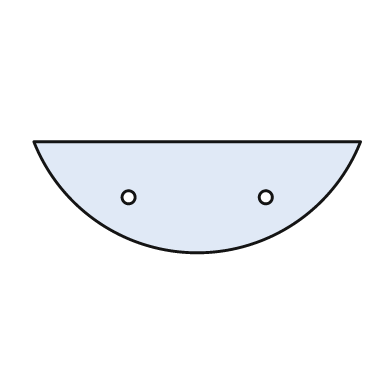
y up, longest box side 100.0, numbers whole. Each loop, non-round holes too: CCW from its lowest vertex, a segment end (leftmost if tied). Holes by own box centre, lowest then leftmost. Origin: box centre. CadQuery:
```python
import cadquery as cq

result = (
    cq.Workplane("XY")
    .moveTo(-50.0, 17.0)
    .threePointArc((0.0, -17.0), (50.0, 17.0))
    .close()
    .moveTo(-21.0, 0.0)
    .circle(2.0)
    .moveTo(21.0, 0.0)
    .circle(2.0)
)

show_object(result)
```